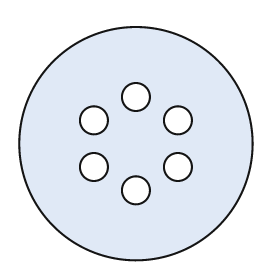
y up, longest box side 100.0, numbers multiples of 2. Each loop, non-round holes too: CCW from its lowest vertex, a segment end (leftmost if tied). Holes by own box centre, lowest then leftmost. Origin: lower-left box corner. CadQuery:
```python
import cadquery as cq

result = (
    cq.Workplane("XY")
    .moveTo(50.0, 50.0)
    .circle(50.0)
    .moveTo(50.0, 30.0)
    .circle(6.0)
    .moveTo(32.0, 40.0)
    .circle(6.0)
    .moveTo(68.0, 40.0)
    .circle(6.0)
    .moveTo(32.0, 60.0)
    .circle(6.0)
    .moveTo(68.0, 60.0)
    .circle(6.0)
    .moveTo(50.0, 70.0)
    .circle(6.0)
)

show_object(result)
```